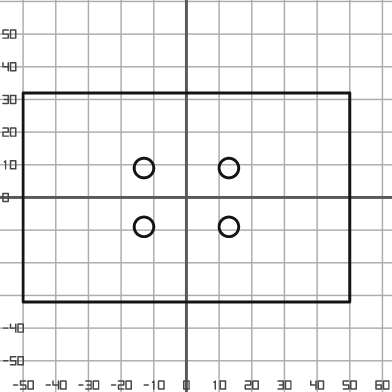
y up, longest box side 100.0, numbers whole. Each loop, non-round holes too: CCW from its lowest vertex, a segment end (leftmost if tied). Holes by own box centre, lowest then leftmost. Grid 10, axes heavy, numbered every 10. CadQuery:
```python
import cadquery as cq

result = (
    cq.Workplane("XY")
    .moveTo(-50.0, -32.0)
    .lineTo(50.0, -32.0)
    .lineTo(50.0, 32.0)
    .lineTo(-50.0, 32.0)
    .close()
    .moveTo(-13.0, -9.0)
    .circle(3.0)
    .moveTo(13.0, -9.0)
    .circle(3.0)
    .moveTo(-13.0, 9.0)
    .circle(3.0)
    .moveTo(13.0, 9.0)
    .circle(3.0)
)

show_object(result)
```